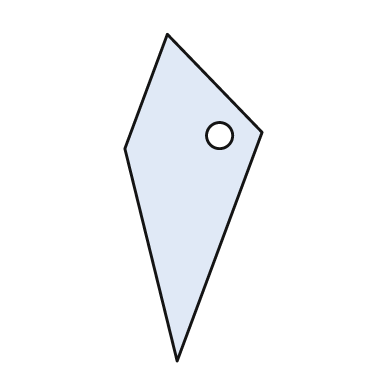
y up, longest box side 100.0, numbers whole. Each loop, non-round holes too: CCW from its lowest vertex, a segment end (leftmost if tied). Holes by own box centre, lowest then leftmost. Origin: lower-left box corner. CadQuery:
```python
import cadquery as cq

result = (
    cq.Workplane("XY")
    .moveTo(16.0, 0.0)
    .lineTo(42.0, 70.0)
    .lineTo(13.0, 100.0)
    .lineTo(0.0, 65.0)
    .close()
    .moveTo(29.0, 69.0)
    .circle(4.0)
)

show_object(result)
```